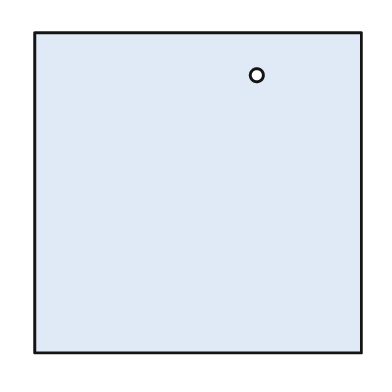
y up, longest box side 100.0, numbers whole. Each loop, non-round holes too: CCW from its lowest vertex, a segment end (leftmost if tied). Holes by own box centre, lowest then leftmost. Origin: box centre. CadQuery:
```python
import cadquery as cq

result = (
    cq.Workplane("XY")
    .moveTo(-50.0, -49.0)
    .lineTo(50.0, -49.0)
    .lineTo(50.0, 49.0)
    .lineTo(-50.0, 49.0)
    .close()
    .moveTo(18.0, 36.0)
    .circle(2.0)
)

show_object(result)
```